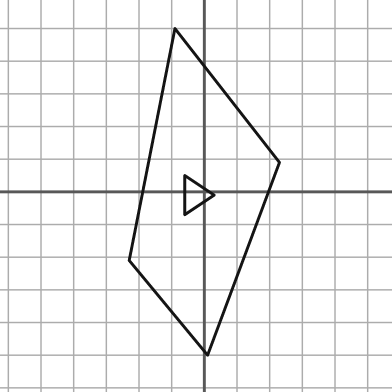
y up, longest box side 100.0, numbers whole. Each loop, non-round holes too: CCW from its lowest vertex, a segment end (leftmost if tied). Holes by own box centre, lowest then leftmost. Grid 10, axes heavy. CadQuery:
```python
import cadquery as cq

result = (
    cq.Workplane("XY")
    .moveTo(1.0, -50.0)
    .lineTo(23.0, 9.0)
    .lineTo(-9.0, 50.0)
    .lineTo(-23.0, -21.0)
    .close()
    .moveTo(-6.0, -7.0)
    .lineTo(3.0, -1.0)
    .lineTo(-6.0, 5.0)
    .close()
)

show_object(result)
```